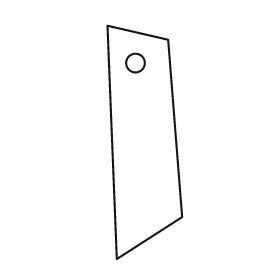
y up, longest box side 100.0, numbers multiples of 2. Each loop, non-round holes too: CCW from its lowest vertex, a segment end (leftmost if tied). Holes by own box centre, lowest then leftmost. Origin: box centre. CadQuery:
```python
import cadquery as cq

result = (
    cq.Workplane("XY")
    .moveTo(-12.0, -50.0)
    .lineTo(16.0, -32.0)
    .lineTo(10.0, 44.0)
    .lineTo(-16.0, 50.0)
    .close()
    .moveTo(-4.0, 34.0)
    .circle(4.0)
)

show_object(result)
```